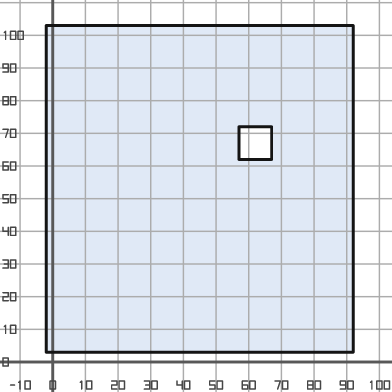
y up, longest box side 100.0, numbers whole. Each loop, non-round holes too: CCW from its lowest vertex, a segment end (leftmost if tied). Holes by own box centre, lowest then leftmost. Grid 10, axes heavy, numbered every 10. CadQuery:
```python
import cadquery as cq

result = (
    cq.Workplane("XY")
    .moveTo(-2.0, 3.0)
    .lineTo(92.0, 3.0)
    .lineTo(92.0, 103.0)
    .lineTo(-2.0, 103.0)
    .close()
    .moveTo(57.0, 62.0)
    .lineTo(67.0, 62.0)
    .lineTo(67.0, 72.0)
    .lineTo(57.0, 72.0)
    .close()
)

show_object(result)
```